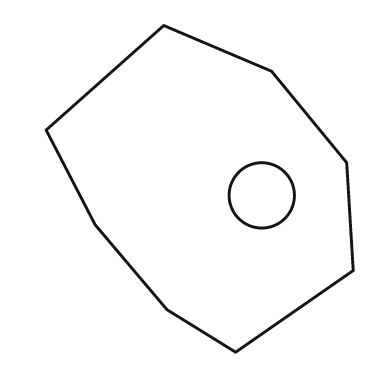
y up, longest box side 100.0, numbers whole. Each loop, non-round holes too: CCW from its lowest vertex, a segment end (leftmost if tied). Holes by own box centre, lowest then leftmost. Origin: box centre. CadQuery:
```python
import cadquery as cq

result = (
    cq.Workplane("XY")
    .moveTo(11.0, -50.0)
    .lineTo(47.0, -25.0)
    .lineTo(45.0, 8.0)
    .lineTo(22.0, 36.0)
    .lineTo(-11.0, 50.0)
    .lineTo(-47.0, 18.0)
    .lineTo(-32.0, -11.0)
    .lineTo(-10.0, -37.0)
    .close()
    .moveTo(19.0, -2.0)
    .circle(10.0)
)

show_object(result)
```